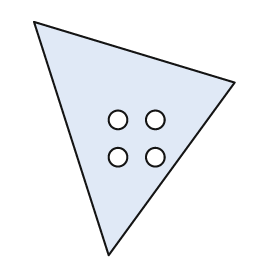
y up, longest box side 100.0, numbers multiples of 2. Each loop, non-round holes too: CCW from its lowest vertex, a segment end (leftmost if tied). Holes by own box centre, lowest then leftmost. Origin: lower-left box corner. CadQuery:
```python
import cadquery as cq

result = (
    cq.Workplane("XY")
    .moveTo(32.0, 0.0)
    .lineTo(86.0, 74.0)
    .lineTo(0.0, 100.0)
    .close()
    .moveTo(36.0, 42.0)
    .circle(4.0)
    .moveTo(52.0, 42.0)
    .circle(4.0)
    .moveTo(36.0, 58.0)
    .circle(4.0)
    .moveTo(52.0, 58.0)
    .circle(4.0)
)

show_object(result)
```